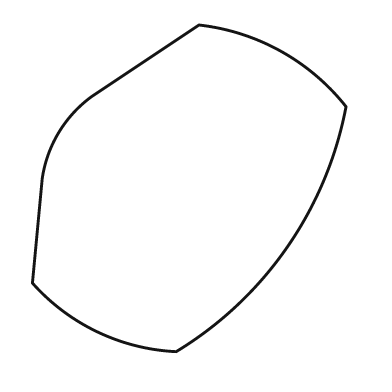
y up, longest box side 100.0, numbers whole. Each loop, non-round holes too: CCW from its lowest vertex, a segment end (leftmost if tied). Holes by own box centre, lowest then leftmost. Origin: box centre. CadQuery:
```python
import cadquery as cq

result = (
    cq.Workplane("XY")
    .moveTo(-4.0, -50.0)
    .threePointArc((30.0, -18.0), (48.0, 25.0))
    .threePointArc((28.0, 42.0), (3.0, 50.0))
    .lineTo(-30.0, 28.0)
    .threePointArc((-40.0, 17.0), (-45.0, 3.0))
    .lineTo(-48.0, -29.0)
    .threePointArc((-28.0, -44.0), (-4.0, -50.0))
    .close()
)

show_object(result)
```